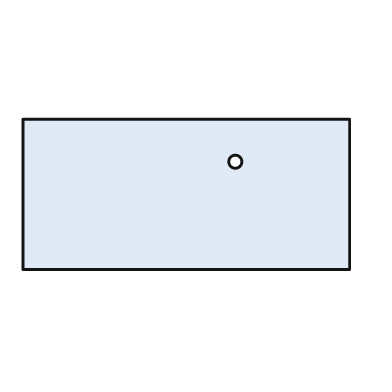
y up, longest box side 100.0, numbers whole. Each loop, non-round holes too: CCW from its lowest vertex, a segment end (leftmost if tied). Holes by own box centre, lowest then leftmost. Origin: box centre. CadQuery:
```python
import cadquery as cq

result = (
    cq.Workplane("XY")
    .moveTo(-50.0, -23.0)
    .lineTo(50.0, -23.0)
    .lineTo(50.0, 23.0)
    .lineTo(-50.0, 23.0)
    .close()
    .moveTo(15.0, 10.0)
    .circle(2.0)
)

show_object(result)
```